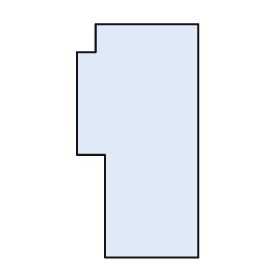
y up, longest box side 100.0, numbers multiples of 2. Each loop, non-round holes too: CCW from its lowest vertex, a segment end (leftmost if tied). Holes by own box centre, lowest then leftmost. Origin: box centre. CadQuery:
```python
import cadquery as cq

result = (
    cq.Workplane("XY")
    .moveTo(-14.0, -50.0)
    .lineTo(26.0, -50.0)
    .lineTo(26.0, 50.0)
    .lineTo(-18.0, 50.0)
    .lineTo(-18.0, 38.0)
    .lineTo(-26.0, 38.0)
    .lineTo(-26.0, -6.0)
    .lineTo(-14.0, -6.0)
    .close()
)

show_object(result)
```